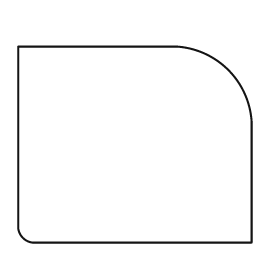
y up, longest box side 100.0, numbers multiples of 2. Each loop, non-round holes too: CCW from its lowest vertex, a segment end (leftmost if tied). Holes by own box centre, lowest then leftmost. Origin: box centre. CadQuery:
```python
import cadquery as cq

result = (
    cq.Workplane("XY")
    .moveTo(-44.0, -42.0)
    .lineTo(50.0, -42.0)
    .lineTo(50.0, 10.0)
    .threePointArc((40.0, 32.0), (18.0, 42.0))
    .lineTo(-50.0, 42.0)
    .lineTo(-50.0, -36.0)
    .threePointArc((-48.0, -40.0), (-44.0, -42.0))
    .close()
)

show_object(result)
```